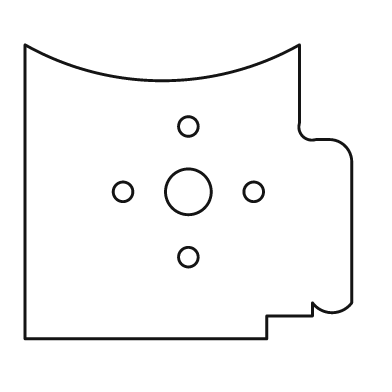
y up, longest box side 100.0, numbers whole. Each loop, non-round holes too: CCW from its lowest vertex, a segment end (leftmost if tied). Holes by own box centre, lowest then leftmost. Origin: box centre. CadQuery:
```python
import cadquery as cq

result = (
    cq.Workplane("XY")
    .moveTo(-50.0, -45.0)
    .lineTo(24.0, -45.0)
    .lineTo(24.0, -38.0)
    .lineTo(38.0, -38.0)
    .lineTo(38.0, -34.0)
    .threePointArc((44.0, -37.0), (50.0, -34.0))
    .lineTo(50.0, 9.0)
    .threePointArc((48.0, 14.0), (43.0, 16.0))
    .lineTo(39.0, 16.0)
    .threePointArc((35.0, 17.0), (34.0, 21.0))
    .lineTo(34.0, 45.0)
    .threePointArc((-8.0, 34.0), (-50.0, 45.0))
    .close()
    .moveTo(0.0, -20.0)
    .circle(3.0)
    .moveTo(-20.0, 0.0)
    .circle(3.0)
    .moveTo(0.0, 0.0)
    .circle(7.0)
    .moveTo(20.0, 0.0)
    .circle(3.0)
    .moveTo(0.0, 20.0)
    .circle(3.0)
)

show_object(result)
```